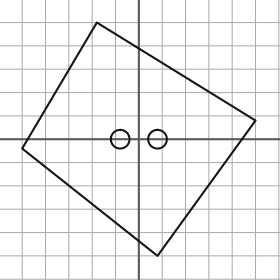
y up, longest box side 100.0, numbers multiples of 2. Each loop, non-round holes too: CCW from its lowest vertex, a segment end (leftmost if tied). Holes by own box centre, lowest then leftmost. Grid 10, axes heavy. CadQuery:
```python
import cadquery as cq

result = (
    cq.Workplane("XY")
    .moveTo(8.0, -50.0)
    .lineTo(50.0, 8.0)
    .lineTo(-18.0, 50.0)
    .lineTo(-50.0, -4.0)
    .close()
    .moveTo(-8.0, 0.0)
    .circle(4.0)
    .moveTo(8.0, 0.0)
    .circle(4.0)
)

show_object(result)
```